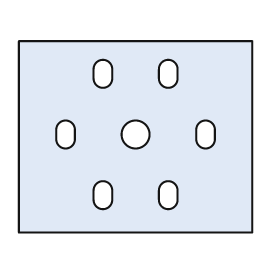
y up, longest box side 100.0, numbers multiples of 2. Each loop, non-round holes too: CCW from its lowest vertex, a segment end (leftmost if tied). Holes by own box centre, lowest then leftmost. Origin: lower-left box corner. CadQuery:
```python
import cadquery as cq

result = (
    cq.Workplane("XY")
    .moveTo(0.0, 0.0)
    .lineTo(100.0, 0.0)
    .lineTo(100.0, 82.0)
    .lineTo(0.0, 82.0)
    .close()
    .moveTo(32.0, 14.0)
    .threePointArc((36.0, 10.0), (40.0, 14.0))
    .lineTo(40.0, 18.0)
    .threePointArc((36.0, 22.0), (32.0, 18.0))
    .close()
    .moveTo(60.0, 14.0)
    .threePointArc((64.0, 10.0), (68.0, 14.0))
    .lineTo(68.0, 18.0)
    .threePointArc((64.0, 22.0), (60.0, 18.0))
    .close()
    .moveTo(16.0, 40.0)
    .threePointArc((20.0, 36.0), (24.0, 40.0))
    .lineTo(24.0, 44.0)
    .threePointArc((20.0, 48.0), (16.0, 44.0))
    .close()
    .moveTo(50.0, 42.0)
    .circle(6.0)
    .moveTo(76.0, 40.0)
    .threePointArc((80.0, 36.0), (84.0, 40.0))
    .lineTo(84.0, 44.0)
    .threePointArc((80.0, 48.0), (76.0, 44.0))
    .close()
    .moveTo(32.0, 66.0)
    .threePointArc((36.0, 62.0), (40.0, 66.0))
    .lineTo(40.0, 70.0)
    .threePointArc((36.0, 74.0), (32.0, 70.0))
    .close()
    .moveTo(60.0, 66.0)
    .threePointArc((64.0, 62.0), (68.0, 66.0))
    .lineTo(68.0, 70.0)
    .threePointArc((64.0, 74.0), (60.0, 70.0))
    .close()
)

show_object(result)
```